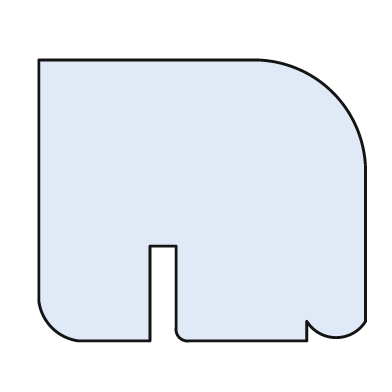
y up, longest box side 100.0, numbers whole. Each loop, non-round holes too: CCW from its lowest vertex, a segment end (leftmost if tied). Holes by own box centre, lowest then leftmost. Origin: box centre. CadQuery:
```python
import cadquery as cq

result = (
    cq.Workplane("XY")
    .moveTo(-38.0, -43.0)
    .lineTo(-16.0, -43.0)
    .lineTo(-16.0, -14.0)
    .lineTo(-8.0, -14.0)
    .lineTo(-8.0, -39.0)
    .threePointArc((-7.0, -42.0), (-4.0, -43.0))
    .lineTo(32.0, -43.0)
    .lineTo(32.0, -37.0)
    .threePointArc((41.0, -42.0), (50.0, -37.0))
    .lineTo(50.0, 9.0)
    .threePointArc((40.0, 33.0), (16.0, 43.0))
    .lineTo(-50.0, 43.0)
    .lineTo(-50.0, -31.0)
    .threePointArc((-46.0, -39.0), (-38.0, -43.0))
    .close()
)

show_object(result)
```